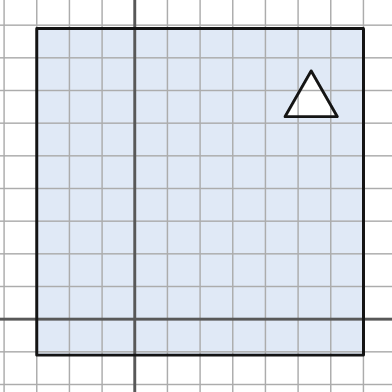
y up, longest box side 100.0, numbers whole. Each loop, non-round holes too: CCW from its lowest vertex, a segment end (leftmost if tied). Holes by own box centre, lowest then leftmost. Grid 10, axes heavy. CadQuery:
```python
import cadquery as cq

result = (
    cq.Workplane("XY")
    .moveTo(-30.0, -11.0)
    .lineTo(70.0, -11.0)
    .lineTo(70.0, 89.0)
    .lineTo(-30.0, 89.0)
    .close()
    .moveTo(46.0, 62.0)
    .lineTo(62.0, 62.0)
    .lineTo(54.0, 76.0)
    .close()
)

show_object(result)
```